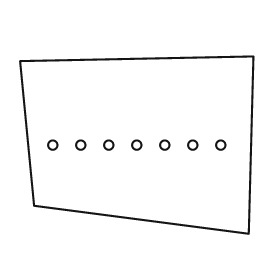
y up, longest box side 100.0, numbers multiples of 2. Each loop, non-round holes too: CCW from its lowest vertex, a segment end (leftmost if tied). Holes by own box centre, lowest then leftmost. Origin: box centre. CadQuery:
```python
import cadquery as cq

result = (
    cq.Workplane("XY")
    .moveTo(48.0, -38.0)
    .lineTo(50.0, 38.0)
    .lineTo(-50.0, 36.0)
    .lineTo(-44.0, -26.0)
    .close()
    .moveTo(-36.0, 0.0)
    .circle(2.0)
    .moveTo(-24.0, 0.0)
    .circle(2.0)
    .moveTo(-12.0, 0.0)
    .circle(2.0)
    .moveTo(0.0, 0.0)
    .circle(2.0)
    .moveTo(12.0, 0.0)
    .circle(2.0)
    .moveTo(24.0, 0.0)
    .circle(2.0)
    .moveTo(36.0, 0.0)
    .circle(2.0)
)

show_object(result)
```